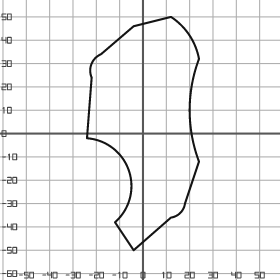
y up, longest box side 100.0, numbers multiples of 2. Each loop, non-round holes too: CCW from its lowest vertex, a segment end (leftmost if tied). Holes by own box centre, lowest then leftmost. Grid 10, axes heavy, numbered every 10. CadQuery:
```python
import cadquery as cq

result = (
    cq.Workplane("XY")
    .moveTo(-4.0, -50.0)
    .lineTo(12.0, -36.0)
    .threePointArc((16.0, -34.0), (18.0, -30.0))
    .lineTo(24.0, -12.0)
    .threePointArc((20.0, 10.0), (24.0, 32.0))
    .threePointArc((20.0, 42.0), (12.0, 50.0))
    .lineTo(-4.0, 46.0)
    .lineTo(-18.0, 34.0)
    .threePointArc((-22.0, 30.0), (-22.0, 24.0))
    .lineTo(-24.0, -2.0)
    .threePointArc((-6.0, -16.0), (-12.0, -38.0))
    .close()
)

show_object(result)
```